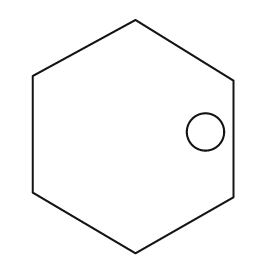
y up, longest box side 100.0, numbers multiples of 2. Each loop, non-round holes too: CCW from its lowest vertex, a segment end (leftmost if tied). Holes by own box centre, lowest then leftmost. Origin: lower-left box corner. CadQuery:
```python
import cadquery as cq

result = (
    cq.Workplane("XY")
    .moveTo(44.0, 0.0)
    .lineTo(86.0, 24.0)
    .lineTo(86.0, 74.0)
    .lineTo(44.0, 100.0)
    .lineTo(0.0, 76.0)
    .lineTo(0.0, 26.0)
    .close()
    .moveTo(74.0, 52.0)
    .circle(8.0)
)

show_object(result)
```